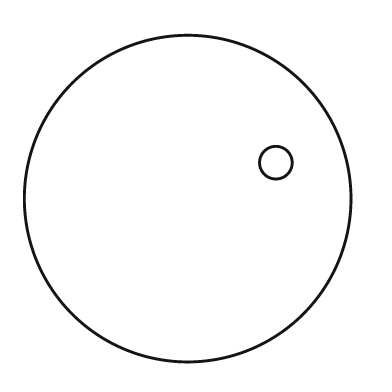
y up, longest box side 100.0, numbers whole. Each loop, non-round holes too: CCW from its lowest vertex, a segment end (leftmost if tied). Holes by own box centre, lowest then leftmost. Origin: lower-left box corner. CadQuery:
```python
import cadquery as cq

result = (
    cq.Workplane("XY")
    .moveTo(50.0, 50.0)
    .circle(50.0)
    .moveTo(77.0, 61.0)
    .circle(5.0)
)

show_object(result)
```